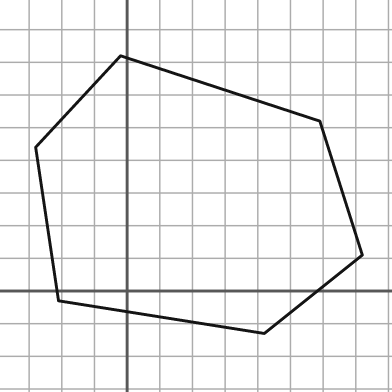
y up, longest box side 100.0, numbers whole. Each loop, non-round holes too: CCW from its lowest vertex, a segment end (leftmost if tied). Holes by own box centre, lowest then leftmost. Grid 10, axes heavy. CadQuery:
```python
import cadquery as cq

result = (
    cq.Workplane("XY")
    .moveTo(42.0, -13.0)
    .lineTo(72.0, 11.0)
    .lineTo(59.0, 52.0)
    .lineTo(-2.0, 72.0)
    .lineTo(-28.0, 44.0)
    .lineTo(-21.0, -3.0)
    .close()
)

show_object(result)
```